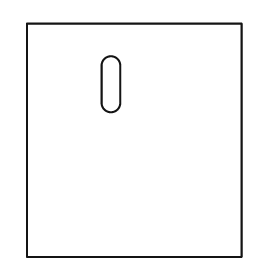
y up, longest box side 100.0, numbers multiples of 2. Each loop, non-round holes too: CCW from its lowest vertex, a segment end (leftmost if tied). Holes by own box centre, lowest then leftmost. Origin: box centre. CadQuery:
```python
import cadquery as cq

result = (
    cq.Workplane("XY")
    .moveTo(-46.0, -50.0)
    .lineTo(46.0, -50.0)
    .lineTo(46.0, 50.0)
    .lineTo(-46.0, 50.0)
    .close()
    .moveTo(-14.0, 16.0)
    .threePointArc((-10.0, 12.0), (-6.0, 16.0))
    .lineTo(-6.0, 32.0)
    .threePointArc((-10.0, 36.0), (-14.0, 32.0))
    .close()
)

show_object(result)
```